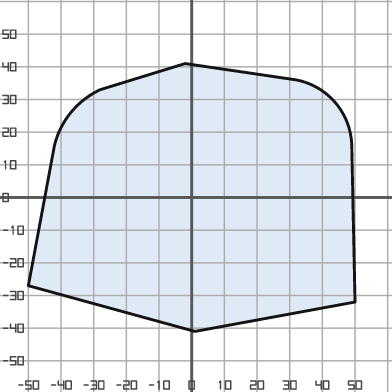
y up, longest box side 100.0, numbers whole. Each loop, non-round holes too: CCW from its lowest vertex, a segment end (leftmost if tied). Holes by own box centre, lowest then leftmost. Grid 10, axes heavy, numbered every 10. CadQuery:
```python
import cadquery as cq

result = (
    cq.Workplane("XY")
    .moveTo(1.0, -41.0)
    .lineTo(50.0, -32.0)
    .lineTo(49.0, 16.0)
    .threePointArc((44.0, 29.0), (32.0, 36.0))
    .lineTo(-2.0, 41.0)
    .lineTo(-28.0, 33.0)
    .threePointArc((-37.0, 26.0), (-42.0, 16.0))
    .lineTo(-50.0, -27.0)
    .close()
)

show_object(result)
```